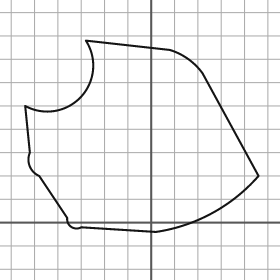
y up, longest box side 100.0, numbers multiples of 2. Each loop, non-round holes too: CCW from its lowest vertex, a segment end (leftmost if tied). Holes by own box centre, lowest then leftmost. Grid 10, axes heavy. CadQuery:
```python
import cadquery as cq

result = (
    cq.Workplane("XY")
    .moveTo(2.0, -4.0)
    .threePointArc((26.0, 4.0), (46.0, 20.0))
    .lineTo(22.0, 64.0)
    .threePointArc((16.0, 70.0), (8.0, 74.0))
    .lineTo(-28.0, 78.0)
    .threePointArc((-30.0, 54.0), (-54.0, 50.0))
    .lineTo(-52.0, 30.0)
    .threePointArc((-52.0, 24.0), (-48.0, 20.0))
    .lineTo(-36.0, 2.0)
    .threePointArc((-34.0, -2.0), (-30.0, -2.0))
    .close()
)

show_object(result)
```